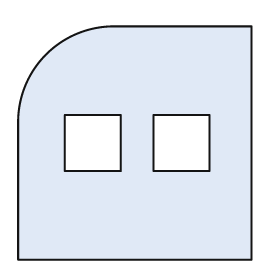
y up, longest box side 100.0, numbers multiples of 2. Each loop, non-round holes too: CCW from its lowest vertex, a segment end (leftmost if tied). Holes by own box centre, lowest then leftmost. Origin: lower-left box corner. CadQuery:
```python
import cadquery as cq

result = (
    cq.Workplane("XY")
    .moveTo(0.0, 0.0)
    .lineTo(100.0, 0.0)
    .lineTo(100.0, 100.0)
    .lineTo(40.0, 100.0)
    .threePointArc((12.0, 88.0), (0.0, 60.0))
    .close()
    .moveTo(20.0, 38.0)
    .lineTo(44.0, 38.0)
    .lineTo(44.0, 62.0)
    .lineTo(20.0, 62.0)
    .close()
    .moveTo(58.0, 38.0)
    .lineTo(82.0, 38.0)
    .lineTo(82.0, 62.0)
    .lineTo(58.0, 62.0)
    .close()
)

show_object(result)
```